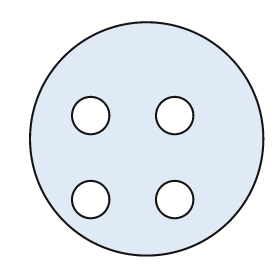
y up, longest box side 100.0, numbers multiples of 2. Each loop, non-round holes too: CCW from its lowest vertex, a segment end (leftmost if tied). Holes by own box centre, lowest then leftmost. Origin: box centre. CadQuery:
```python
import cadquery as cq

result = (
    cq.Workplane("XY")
    .moveTo(0.0, 0.0)
    .circle(50.0)
    .moveTo(-24.0, -26.0)
    .circle(8.0)
    .moveTo(12.0, -26.0)
    .circle(8.0)
    .moveTo(-24.0, 10.0)
    .circle(8.0)
    .moveTo(12.0, 10.0)
    .circle(8.0)
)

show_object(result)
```